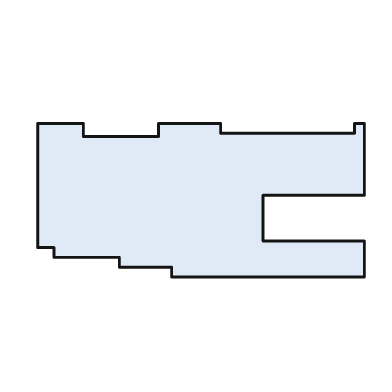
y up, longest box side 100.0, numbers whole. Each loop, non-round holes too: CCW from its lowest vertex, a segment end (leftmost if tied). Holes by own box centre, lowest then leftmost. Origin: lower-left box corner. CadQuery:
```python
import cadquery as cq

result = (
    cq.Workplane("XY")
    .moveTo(41.0, 0.0)
    .lineTo(100.0, 0.0)
    .lineTo(100.0, 11.0)
    .lineTo(69.0, 11.0)
    .lineTo(69.0, 25.0)
    .lineTo(100.0, 25.0)
    .lineTo(100.0, 47.0)
    .lineTo(97.0, 47.0)
    .lineTo(97.0, 44.0)
    .lineTo(56.0, 44.0)
    .lineTo(56.0, 47.0)
    .lineTo(37.0, 47.0)
    .lineTo(37.0, 43.0)
    .lineTo(14.0, 43.0)
    .lineTo(14.0, 47.0)
    .lineTo(0.0, 47.0)
    .lineTo(0.0, 9.0)
    .lineTo(5.0, 9.0)
    .lineTo(5.0, 6.0)
    .lineTo(25.0, 6.0)
    .lineTo(25.0, 3.0)
    .lineTo(41.0, 3.0)
    .close()
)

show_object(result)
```